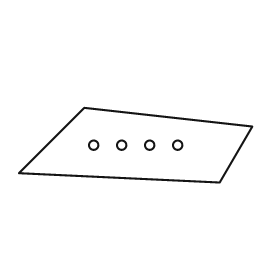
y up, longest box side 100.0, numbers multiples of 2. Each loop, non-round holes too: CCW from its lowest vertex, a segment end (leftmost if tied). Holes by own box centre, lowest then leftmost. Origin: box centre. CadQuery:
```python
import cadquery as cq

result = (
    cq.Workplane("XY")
    .moveTo(36.0, -16.0)
    .lineTo(50.0, 8.0)
    .lineTo(-22.0, 16.0)
    .lineTo(-50.0, -12.0)
    .close()
    .moveTo(-18.0, 0.0)
    .circle(2.0)
    .moveTo(-6.0, 0.0)
    .circle(2.0)
    .moveTo(6.0, 0.0)
    .circle(2.0)
    .moveTo(18.0, 0.0)
    .circle(2.0)
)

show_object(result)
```